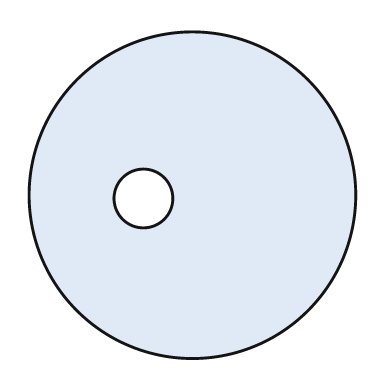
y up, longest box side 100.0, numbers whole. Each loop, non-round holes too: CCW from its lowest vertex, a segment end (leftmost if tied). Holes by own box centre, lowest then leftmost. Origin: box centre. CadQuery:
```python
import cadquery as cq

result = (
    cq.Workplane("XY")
    .moveTo(0.0, 0.0)
    .circle(50.0)
    .moveTo(-15.0, -1.0)
    .circle(9.0)
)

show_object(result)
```